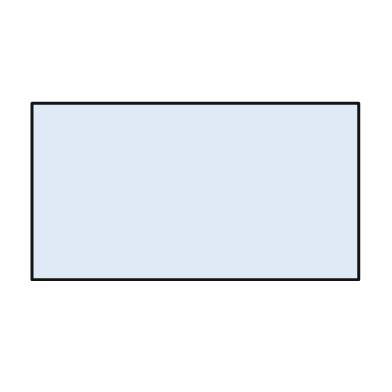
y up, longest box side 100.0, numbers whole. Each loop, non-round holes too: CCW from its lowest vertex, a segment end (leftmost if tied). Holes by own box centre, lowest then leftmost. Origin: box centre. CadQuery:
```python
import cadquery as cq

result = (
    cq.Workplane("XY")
    .moveTo(-50.0, -27.0)
    .lineTo(50.0, -27.0)
    .lineTo(50.0, 27.0)
    .lineTo(-50.0, 27.0)
    .close()
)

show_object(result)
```